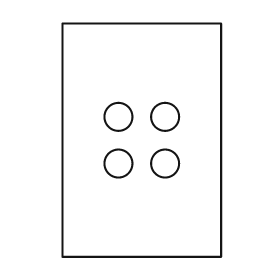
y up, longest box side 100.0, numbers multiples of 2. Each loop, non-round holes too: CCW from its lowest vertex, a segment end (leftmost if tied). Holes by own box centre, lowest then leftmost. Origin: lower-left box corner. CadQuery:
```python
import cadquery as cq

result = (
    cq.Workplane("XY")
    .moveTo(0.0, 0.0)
    .lineTo(68.0, 0.0)
    .lineTo(68.0, 100.0)
    .lineTo(0.0, 100.0)
    .close()
    .moveTo(24.0, 40.0)
    .circle(6.0)
    .moveTo(44.0, 40.0)
    .circle(6.0)
    .moveTo(24.0, 60.0)
    .circle(6.0)
    .moveTo(44.0, 60.0)
    .circle(6.0)
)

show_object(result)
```